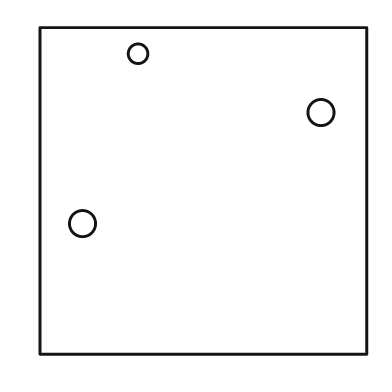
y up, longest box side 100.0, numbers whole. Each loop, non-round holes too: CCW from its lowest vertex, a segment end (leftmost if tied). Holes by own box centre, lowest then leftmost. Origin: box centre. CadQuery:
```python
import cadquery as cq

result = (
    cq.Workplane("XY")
    .moveTo(-50.0, -50.0)
    .lineTo(50.0, -50.0)
    .lineTo(50.0, 50.0)
    .lineTo(-50.0, 50.0)
    .close()
    .moveTo(-37.0, -10.0)
    .circle(4.0)
    .moveTo(36.0, 24.0)
    .circle(4.0)
    .moveTo(-20.0, 42.0)
    .circle(3.0)
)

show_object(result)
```